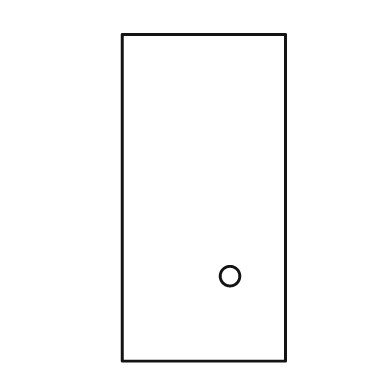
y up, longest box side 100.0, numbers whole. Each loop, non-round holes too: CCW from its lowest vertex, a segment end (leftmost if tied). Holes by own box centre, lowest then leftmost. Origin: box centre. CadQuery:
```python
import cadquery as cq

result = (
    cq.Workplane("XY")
    .moveTo(-25.0, -50.0)
    .lineTo(25.0, -50.0)
    .lineTo(25.0, 50.0)
    .lineTo(-25.0, 50.0)
    .close()
    .moveTo(8.0, -24.0)
    .circle(3.0)
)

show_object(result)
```